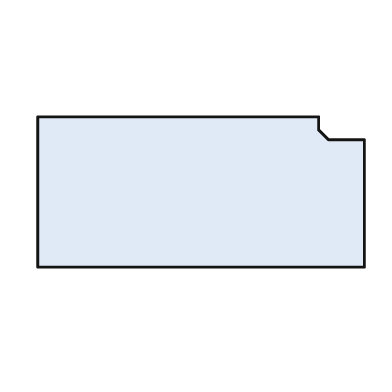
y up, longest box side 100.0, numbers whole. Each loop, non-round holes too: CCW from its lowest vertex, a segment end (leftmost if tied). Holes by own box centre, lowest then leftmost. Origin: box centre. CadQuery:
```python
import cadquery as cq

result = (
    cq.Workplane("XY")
    .moveTo(-50.0, -23.0)
    .lineTo(50.0, -23.0)
    .lineTo(50.0, 16.0)
    .lineTo(39.0, 16.0)
    .lineTo(36.0, 19.0)
    .lineTo(36.0, 23.0)
    .lineTo(-50.0, 23.0)
    .close()
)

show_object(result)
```